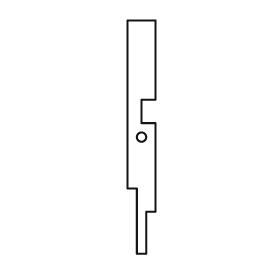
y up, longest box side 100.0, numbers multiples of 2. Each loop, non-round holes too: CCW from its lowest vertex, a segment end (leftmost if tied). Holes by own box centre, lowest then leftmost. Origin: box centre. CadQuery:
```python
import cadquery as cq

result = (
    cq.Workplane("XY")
    .moveTo(-2.0, -50.0)
    .lineTo(2.0, -50.0)
    .lineTo(2.0, -32.0)
    .lineTo(6.0, -32.0)
    .lineTo(6.0, 6.0)
    .lineTo(0.0, 6.0)
    .lineTo(0.0, 16.0)
    .lineTo(6.0, 16.0)
    .lineTo(6.0, 50.0)
    .lineTo(-6.0, 50.0)
    .lineTo(-6.0, -22.0)
    .lineTo(-2.0, -22.0)
    .close()
    .moveTo(0.0, 0.0)
    .circle(2.0)
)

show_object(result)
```